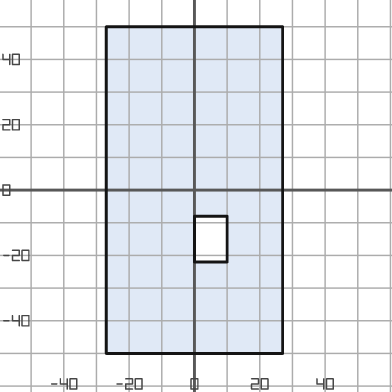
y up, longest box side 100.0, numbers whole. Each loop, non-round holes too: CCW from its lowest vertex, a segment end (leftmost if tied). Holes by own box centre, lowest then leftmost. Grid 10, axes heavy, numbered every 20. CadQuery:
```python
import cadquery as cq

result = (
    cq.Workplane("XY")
    .moveTo(-27.0, -50.0)
    .lineTo(27.0, -50.0)
    .lineTo(27.0, 50.0)
    .lineTo(-27.0, 50.0)
    .close()
    .moveTo(0.0, -22.0)
    .lineTo(10.0, -22.0)
    .lineTo(10.0, -8.0)
    .lineTo(0.0, -8.0)
    .close()
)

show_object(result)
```